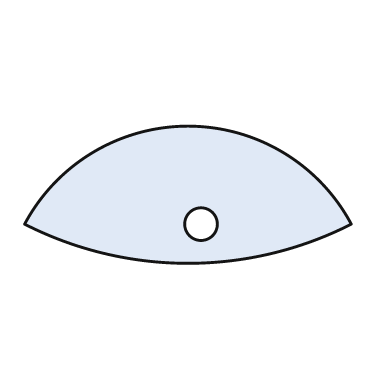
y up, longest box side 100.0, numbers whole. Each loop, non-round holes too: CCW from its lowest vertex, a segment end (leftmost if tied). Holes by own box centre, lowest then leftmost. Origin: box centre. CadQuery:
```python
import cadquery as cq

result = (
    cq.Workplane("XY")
    .moveTo(-50.0, -9.0)
    .threePointArc((0.0, -21.0), (50.0, -9.0))
    .threePointArc((0.0, 21.0), (-50.0, -9.0))
    .close()
    .moveTo(4.0, -9.0)
    .circle(5.0)
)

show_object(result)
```